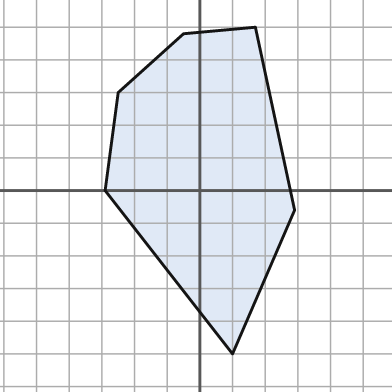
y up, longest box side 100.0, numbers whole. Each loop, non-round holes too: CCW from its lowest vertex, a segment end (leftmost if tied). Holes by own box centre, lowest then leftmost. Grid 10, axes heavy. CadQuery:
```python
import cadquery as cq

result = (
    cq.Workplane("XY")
    .moveTo(10.0, -50.0)
    .lineTo(29.0, -6.0)
    .lineTo(17.0, 50.0)
    .lineTo(-5.0, 48.0)
    .lineTo(-25.0, 30.0)
    .lineTo(-29.0, 0.0)
    .close()
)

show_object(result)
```